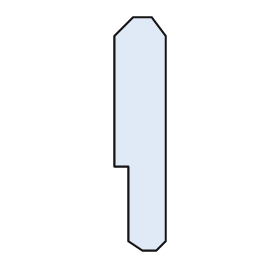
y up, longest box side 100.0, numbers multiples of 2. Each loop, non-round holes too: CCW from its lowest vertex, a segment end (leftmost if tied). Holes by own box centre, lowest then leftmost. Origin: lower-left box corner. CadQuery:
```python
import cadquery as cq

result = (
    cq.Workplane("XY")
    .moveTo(12.0, 0.0)
    .lineTo(18.0, 0.0)
    .lineTo(22.0, 4.0)
    .lineTo(22.0, 92.0)
    .lineTo(16.0, 100.0)
    .lineTo(8.0, 100.0)
    .lineTo(0.0, 92.0)
    .lineTo(0.0, 36.0)
    .lineTo(6.0, 36.0)
    .lineTo(6.0, 4.0)
    .close()
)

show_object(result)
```